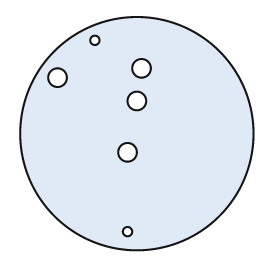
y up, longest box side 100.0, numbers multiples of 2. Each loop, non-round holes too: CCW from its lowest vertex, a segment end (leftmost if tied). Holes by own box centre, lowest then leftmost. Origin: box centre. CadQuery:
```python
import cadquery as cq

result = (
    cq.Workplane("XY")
    .moveTo(0.0, 0.0)
    .circle(50.0)
    .moveTo(-4.0, -42.0)
    .circle(2.0)
    .moveTo(-4.0, -8.0)
    .circle(4.0)
    .moveTo(0.0, 14.0)
    .circle(4.0)
    .moveTo(-34.0, 24.0)
    .circle(4.0)
    .moveTo(2.0, 28.0)
    .circle(4.0)
    .moveTo(-18.0, 40.0)
    .circle(2.0)
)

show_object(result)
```